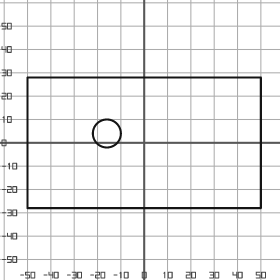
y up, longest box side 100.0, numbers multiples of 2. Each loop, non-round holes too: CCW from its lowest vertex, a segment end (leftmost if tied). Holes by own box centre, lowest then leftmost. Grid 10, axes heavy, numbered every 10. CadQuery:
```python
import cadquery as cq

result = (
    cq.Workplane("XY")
    .moveTo(-50.0, -28.0)
    .lineTo(50.0, -28.0)
    .lineTo(50.0, 28.0)
    .lineTo(-50.0, 28.0)
    .close()
    .moveTo(-16.0, 4.0)
    .circle(6.0)
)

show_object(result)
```